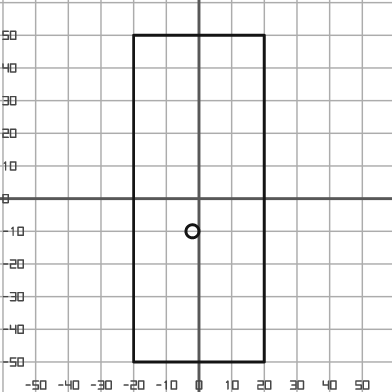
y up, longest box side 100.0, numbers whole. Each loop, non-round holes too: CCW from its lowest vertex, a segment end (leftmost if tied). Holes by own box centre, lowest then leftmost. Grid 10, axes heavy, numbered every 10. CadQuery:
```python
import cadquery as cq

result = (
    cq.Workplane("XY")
    .moveTo(-20.0, -50.0)
    .lineTo(20.0, -50.0)
    .lineTo(20.0, 50.0)
    .lineTo(-20.0, 50.0)
    .close()
    .moveTo(-2.0, -10.0)
    .circle(2.0)
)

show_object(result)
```